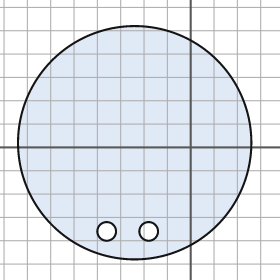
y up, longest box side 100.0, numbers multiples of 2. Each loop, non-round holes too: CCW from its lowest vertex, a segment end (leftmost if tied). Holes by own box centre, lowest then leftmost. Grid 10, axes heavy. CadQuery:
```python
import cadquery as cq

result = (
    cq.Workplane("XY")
    .moveTo(-24.0, 2.0)
    .circle(50.0)
    .moveTo(-36.0, -36.0)
    .circle(4.0)
    .moveTo(-18.0, -36.0)
    .circle(4.0)
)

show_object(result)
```